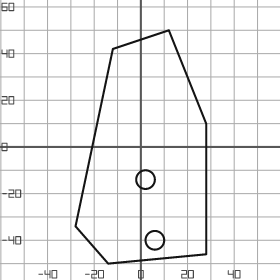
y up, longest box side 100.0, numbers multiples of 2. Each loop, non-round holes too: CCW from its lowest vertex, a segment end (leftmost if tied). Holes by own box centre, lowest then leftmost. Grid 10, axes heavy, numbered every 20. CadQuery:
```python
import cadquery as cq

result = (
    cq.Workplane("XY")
    .moveTo(-14.0, -50.0)
    .lineTo(28.0, -46.0)
    .lineTo(28.0, 10.0)
    .lineTo(12.0, 50.0)
    .lineTo(-12.0, 42.0)
    .lineTo(-28.0, -34.0)
    .close()
    .moveTo(6.0, -40.0)
    .circle(4.0)
    .moveTo(2.0, -14.0)
    .circle(4.0)
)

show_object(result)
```